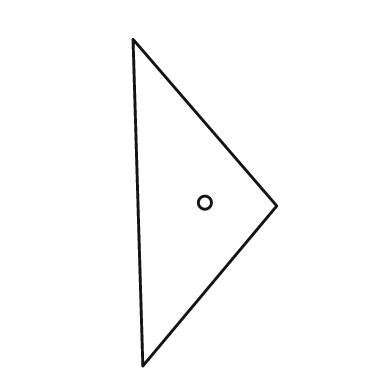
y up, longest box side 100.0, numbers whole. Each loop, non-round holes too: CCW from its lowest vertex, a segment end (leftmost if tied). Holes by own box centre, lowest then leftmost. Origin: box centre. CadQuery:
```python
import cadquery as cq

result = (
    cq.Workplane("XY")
    .moveTo(-19.0, -50.0)
    .lineTo(22.0, -1.0)
    .lineTo(-22.0, 50.0)
    .close()
    .moveTo(0.0, 0.0)
    .circle(2.0)
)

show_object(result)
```